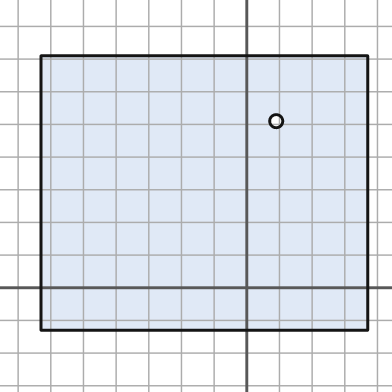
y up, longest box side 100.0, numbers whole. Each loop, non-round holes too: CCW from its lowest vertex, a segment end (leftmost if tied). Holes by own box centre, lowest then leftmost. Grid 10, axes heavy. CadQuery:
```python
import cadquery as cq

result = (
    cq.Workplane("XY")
    .moveTo(-63.0, -13.0)
    .lineTo(37.0, -13.0)
    .lineTo(37.0, 71.0)
    .lineTo(-63.0, 71.0)
    .close()
    .moveTo(9.0, 51.0)
    .circle(2.0)
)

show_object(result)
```